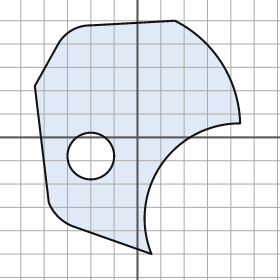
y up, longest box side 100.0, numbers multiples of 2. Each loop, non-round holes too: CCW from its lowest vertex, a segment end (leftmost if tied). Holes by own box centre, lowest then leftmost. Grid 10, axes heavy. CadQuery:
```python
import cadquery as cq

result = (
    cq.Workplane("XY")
    .moveTo(6.0, -50.0)
    .threePointArc((10.0, -12.0), (44.0, 6.0))
    .threePointArc((36.0, 32.0), (16.0, 50.0))
    .lineTo(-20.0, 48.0)
    .threePointArc((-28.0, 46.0), (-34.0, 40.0))
    .lineTo(-44.0, 22.0)
    .lineTo(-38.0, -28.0)
    .threePointArc((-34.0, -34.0), (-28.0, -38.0))
    .close()
    .moveTo(-20.0, -8.0)
    .circle(10.0)
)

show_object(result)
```